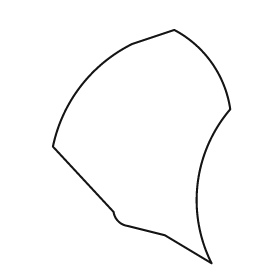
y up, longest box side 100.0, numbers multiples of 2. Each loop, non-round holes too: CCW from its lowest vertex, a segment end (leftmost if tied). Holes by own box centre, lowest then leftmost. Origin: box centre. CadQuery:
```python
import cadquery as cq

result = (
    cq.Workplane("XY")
    .moveTo(30.0, -50.0)
    .threePointArc((24.0, -16.0), (38.0, 16.0))
    .threePointArc((30.0, 36.0), (14.0, 50.0))
    .lineTo(-4.0, 44.0)
    .threePointArc((-26.0, 26.0), (-38.0, 0.0))
    .lineTo(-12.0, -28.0)
    .threePointArc((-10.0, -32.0), (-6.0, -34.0))
    .lineTo(10.0, -38.0)
    .close()
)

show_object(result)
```